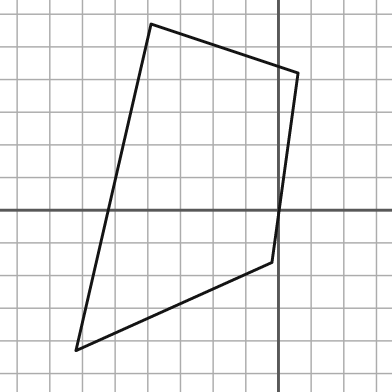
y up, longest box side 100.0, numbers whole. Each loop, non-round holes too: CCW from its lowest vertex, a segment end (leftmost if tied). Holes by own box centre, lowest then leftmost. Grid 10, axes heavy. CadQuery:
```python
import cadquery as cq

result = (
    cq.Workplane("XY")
    .moveTo(-62.0, -43.0)
    .lineTo(-2.0, -16.0)
    .lineTo(6.0, 42.0)
    .lineTo(-39.0, 57.0)
    .close()
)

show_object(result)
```